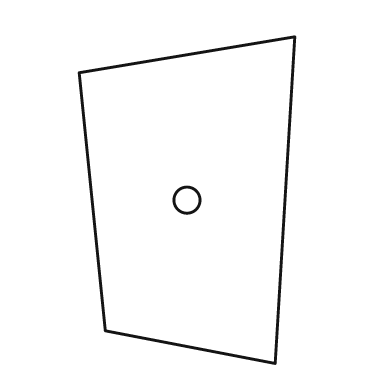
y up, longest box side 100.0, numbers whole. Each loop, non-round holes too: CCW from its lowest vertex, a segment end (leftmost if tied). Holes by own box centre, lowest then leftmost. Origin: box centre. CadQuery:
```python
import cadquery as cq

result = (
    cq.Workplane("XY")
    .moveTo(27.0, -50.0)
    .lineTo(33.0, 50.0)
    .lineTo(-33.0, 39.0)
    .lineTo(-25.0, -40.0)
    .close()
    .moveTo(0.0, 0.0)
    .circle(4.0)
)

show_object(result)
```